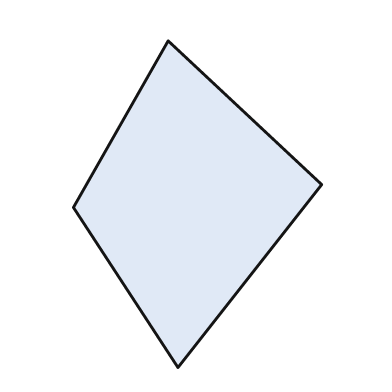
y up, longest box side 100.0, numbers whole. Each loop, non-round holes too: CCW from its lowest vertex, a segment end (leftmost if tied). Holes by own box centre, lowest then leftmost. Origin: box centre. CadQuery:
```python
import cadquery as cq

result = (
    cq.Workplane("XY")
    .moveTo(-6.0, -50.0)
    .lineTo(38.0, 6.0)
    .lineTo(-9.0, 50.0)
    .lineTo(-38.0, -1.0)
    .close()
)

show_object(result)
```